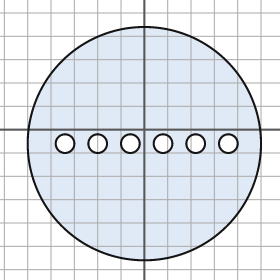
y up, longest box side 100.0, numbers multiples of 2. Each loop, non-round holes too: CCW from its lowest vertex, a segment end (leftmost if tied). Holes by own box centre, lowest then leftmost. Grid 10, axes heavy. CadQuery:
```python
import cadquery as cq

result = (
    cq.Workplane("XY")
    .moveTo(0.0, -6.0)
    .circle(50.0)
    .moveTo(-34.0, -6.0)
    .circle(4.0)
    .moveTo(-20.0, -6.0)
    .circle(4.0)
    .moveTo(-6.0, -6.0)
    .circle(4.0)
    .moveTo(8.0, -6.0)
    .circle(4.0)
    .moveTo(22.0, -6.0)
    .circle(4.0)
    .moveTo(36.0, -6.0)
    .circle(4.0)
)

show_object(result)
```